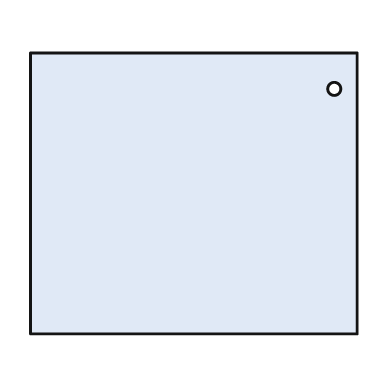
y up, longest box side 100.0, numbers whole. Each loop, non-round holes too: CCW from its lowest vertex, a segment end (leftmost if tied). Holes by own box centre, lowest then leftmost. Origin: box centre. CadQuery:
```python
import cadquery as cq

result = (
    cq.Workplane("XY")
    .moveTo(-50.0, -43.0)
    .lineTo(50.0, -43.0)
    .lineTo(50.0, 43.0)
    .lineTo(-50.0, 43.0)
    .close()
    .moveTo(43.0, 32.0)
    .circle(2.0)
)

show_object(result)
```